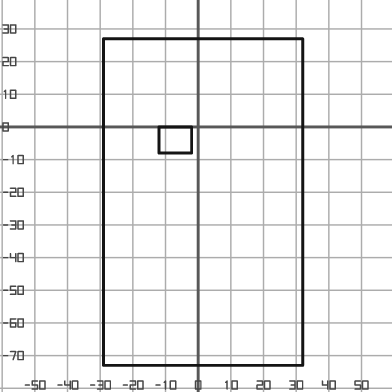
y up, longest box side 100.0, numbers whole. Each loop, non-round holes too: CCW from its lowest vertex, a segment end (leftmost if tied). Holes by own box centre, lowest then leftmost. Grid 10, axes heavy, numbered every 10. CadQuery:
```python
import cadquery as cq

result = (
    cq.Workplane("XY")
    .moveTo(-29.0, -73.0)
    .lineTo(32.0, -73.0)
    .lineTo(32.0, 27.0)
    .lineTo(-29.0, 27.0)
    .close()
    .moveTo(-12.0, -8.0)
    .lineTo(-2.0, -8.0)
    .lineTo(-2.0, 0.0)
    .lineTo(-12.0, 0.0)
    .close()
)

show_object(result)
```